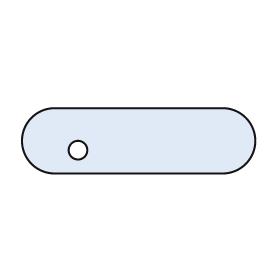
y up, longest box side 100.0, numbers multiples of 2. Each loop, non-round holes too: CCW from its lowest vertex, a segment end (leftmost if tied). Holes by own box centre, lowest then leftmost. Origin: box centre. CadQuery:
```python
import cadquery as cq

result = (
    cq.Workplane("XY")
    .moveTo(-36.0, -14.0)
    .lineTo(36.0, -14.0)
    .threePointArc((50.0, 0.0), (36.0, 14.0))
    .lineTo(-36.0, 14.0)
    .threePointArc((-50.0, 0.0), (-36.0, -14.0))
    .close()
    .moveTo(-26.0, -4.0)
    .circle(4.0)
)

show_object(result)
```